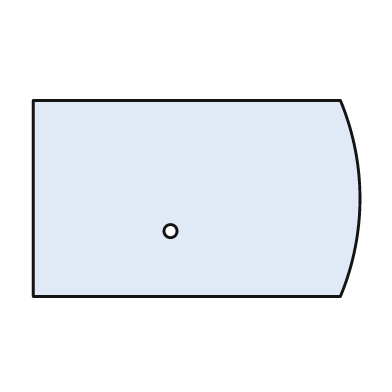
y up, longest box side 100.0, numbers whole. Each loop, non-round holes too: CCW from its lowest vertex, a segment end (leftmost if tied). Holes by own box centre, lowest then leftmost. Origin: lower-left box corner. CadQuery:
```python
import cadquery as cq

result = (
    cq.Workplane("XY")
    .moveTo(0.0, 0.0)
    .lineTo(94.0, 0.0)
    .threePointArc((100.0, 30.0), (94.0, 60.0))
    .lineTo(0.0, 60.0)
    .close()
    .moveTo(42.0, 20.0)
    .circle(2.0)
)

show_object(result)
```